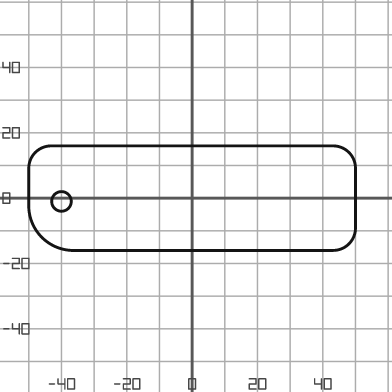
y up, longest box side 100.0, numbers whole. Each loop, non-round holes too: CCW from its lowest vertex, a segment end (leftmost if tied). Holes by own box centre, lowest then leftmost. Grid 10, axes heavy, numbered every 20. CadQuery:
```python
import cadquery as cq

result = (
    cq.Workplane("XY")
    .moveTo(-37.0, -16.0)
    .lineTo(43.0, -16.0)
    .threePointArc((48.0, -14.0), (50.0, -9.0))
    .lineTo(50.0, 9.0)
    .threePointArc((48.0, 14.0), (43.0, 16.0))
    .lineTo(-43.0, 16.0)
    .threePointArc((-48.0, 14.0), (-50.0, 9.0))
    .lineTo(-50.0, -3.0)
    .threePointArc((-46.0, -12.0), (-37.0, -16.0))
    .close()
    .moveTo(-40.0, -1.0)
    .circle(3.0)
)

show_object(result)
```